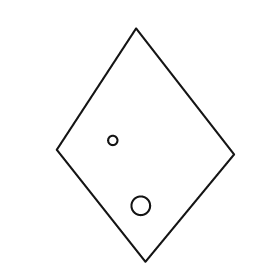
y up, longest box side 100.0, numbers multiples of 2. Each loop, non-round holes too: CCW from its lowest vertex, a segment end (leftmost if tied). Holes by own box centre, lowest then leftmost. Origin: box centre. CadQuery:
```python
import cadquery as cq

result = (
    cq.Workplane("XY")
    .moveTo(0.0, -50.0)
    .lineTo(38.0, -4.0)
    .lineTo(-4.0, 50.0)
    .lineTo(-38.0, -2.0)
    .close()
    .moveTo(-2.0, -26.0)
    .circle(4.0)
    .moveTo(-14.0, 2.0)
    .circle(2.0)
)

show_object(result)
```